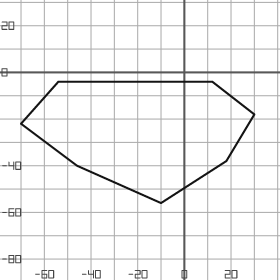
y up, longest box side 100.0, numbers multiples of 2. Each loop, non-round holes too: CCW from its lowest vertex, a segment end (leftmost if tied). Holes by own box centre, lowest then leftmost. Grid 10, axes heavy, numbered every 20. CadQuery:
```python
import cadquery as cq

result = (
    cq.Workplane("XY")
    .moveTo(-10.0, -56.0)
    .lineTo(18.0, -38.0)
    .lineTo(30.0, -18.0)
    .lineTo(12.0, -4.0)
    .lineTo(-54.0, -4.0)
    .lineTo(-70.0, -22.0)
    .lineTo(-46.0, -40.0)
    .close()
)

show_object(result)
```